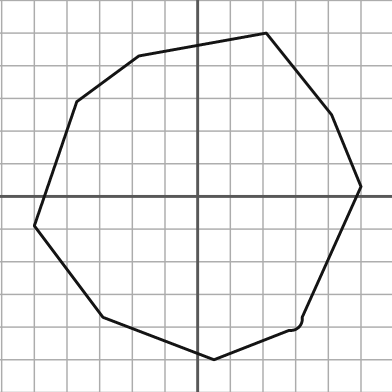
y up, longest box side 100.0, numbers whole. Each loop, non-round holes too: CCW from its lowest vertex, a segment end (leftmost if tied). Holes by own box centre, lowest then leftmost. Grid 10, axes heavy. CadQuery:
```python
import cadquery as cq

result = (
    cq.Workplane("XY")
    .moveTo(5.0, -50.0)
    .lineTo(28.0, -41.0)
    .threePointArc((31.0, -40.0), (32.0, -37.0))
    .lineTo(50.0, 3.0)
    .lineTo(41.0, 25.0)
    .lineTo(21.0, 50.0)
    .lineTo(-18.0, 43.0)
    .lineTo(-37.0, 29.0)
    .lineTo(-50.0, -9.0)
    .lineTo(-29.0, -37.0)
    .close()
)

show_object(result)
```